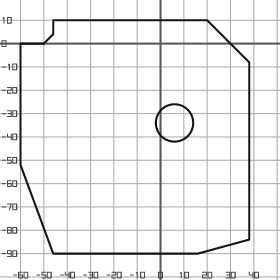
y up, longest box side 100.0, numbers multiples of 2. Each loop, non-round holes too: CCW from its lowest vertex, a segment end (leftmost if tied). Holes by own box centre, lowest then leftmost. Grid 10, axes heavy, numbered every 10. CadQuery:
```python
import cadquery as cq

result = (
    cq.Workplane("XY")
    .moveTo(-46.0, -90.0)
    .lineTo(16.0, -90.0)
    .lineTo(38.0, -84.0)
    .lineTo(38.0, -8.0)
    .lineTo(20.0, 10.0)
    .lineTo(-46.0, 10.0)
    .lineTo(-46.0, 4.0)
    .lineTo(-50.0, 0.0)
    .lineTo(-60.0, 0.0)
    .lineTo(-60.0, -52.0)
    .close()
    .moveTo(6.0, -34.0)
    .circle(8.0)
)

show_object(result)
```